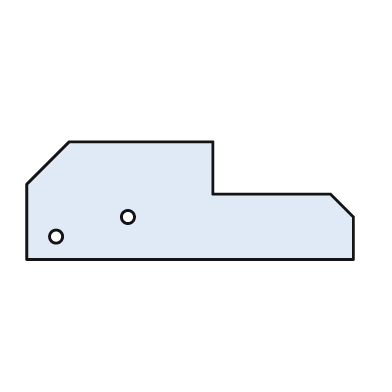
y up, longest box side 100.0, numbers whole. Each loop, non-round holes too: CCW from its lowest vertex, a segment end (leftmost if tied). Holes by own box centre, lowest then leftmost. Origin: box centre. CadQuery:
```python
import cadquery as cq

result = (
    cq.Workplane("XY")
    .moveTo(-50.0, -18.0)
    .lineTo(50.0, -18.0)
    .lineTo(50.0, -5.0)
    .lineTo(43.0, 2.0)
    .lineTo(7.0, 2.0)
    .lineTo(7.0, 18.0)
    .lineTo(-37.0, 18.0)
    .lineTo(-50.0, 5.0)
    .close()
    .moveTo(-41.0, -11.0)
    .circle(2.0)
    .moveTo(-19.0, -5.0)
    .circle(2.0)
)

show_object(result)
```